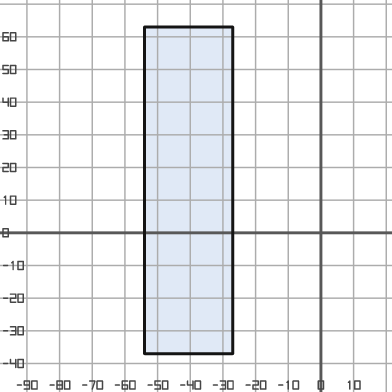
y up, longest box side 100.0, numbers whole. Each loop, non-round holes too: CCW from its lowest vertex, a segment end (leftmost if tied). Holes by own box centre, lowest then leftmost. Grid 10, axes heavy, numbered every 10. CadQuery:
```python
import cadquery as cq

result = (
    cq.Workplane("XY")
    .moveTo(-54.0, -37.0)
    .lineTo(-27.0, -37.0)
    .lineTo(-27.0, 63.0)
    .lineTo(-54.0, 63.0)
    .close()
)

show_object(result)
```